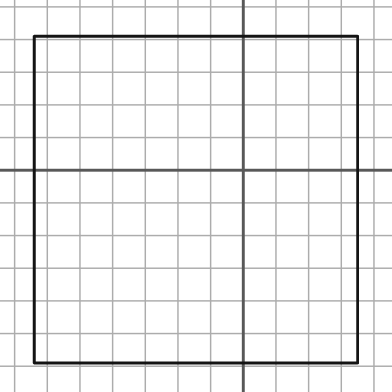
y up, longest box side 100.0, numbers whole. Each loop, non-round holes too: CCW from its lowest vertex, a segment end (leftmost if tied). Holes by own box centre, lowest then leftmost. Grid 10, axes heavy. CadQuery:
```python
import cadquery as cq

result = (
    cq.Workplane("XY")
    .moveTo(-64.0, -59.0)
    .lineTo(35.0, -59.0)
    .lineTo(35.0, 41.0)
    .lineTo(-64.0, 41.0)
    .close()
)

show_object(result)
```